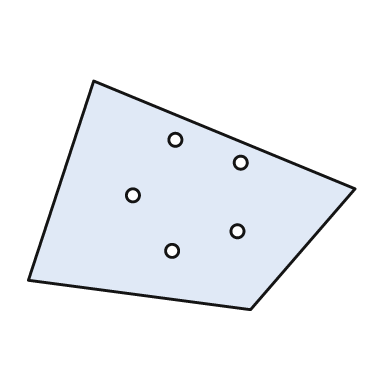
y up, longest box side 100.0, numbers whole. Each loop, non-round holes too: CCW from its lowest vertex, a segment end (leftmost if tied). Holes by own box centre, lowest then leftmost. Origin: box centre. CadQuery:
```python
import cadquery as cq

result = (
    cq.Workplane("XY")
    .moveTo(18.0, -35.0)
    .lineTo(50.0, 2.0)
    .lineTo(-30.0, 35.0)
    .lineTo(-50.0, -26.0)
    .close()
    .moveTo(-6.0, -17.0)
    .circle(2.0)
    .moveTo(14.0, -11.0)
    .circle(2.0)
    .moveTo(-18.0, 0.0)
    .circle(2.0)
    .moveTo(15.0, 10.0)
    .circle(2.0)
    .moveTo(-5.0, 17.0)
    .circle(2.0)
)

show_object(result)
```